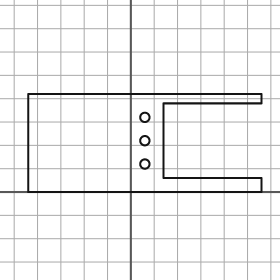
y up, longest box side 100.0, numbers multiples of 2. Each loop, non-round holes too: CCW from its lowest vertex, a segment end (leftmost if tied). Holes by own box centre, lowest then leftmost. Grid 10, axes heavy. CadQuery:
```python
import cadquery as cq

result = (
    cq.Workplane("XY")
    .moveTo(-44.0, 0.0)
    .lineTo(56.0, 0.0)
    .lineTo(56.0, 6.0)
    .lineTo(14.0, 6.0)
    .lineTo(14.0, 38.0)
    .lineTo(56.0, 38.0)
    .lineTo(56.0, 42.0)
    .lineTo(-44.0, 42.0)
    .close()
    .moveTo(6.0, 12.0)
    .circle(2.0)
    .moveTo(6.0, 22.0)
    .circle(2.0)
    .moveTo(6.0, 32.0)
    .circle(2.0)
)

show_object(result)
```